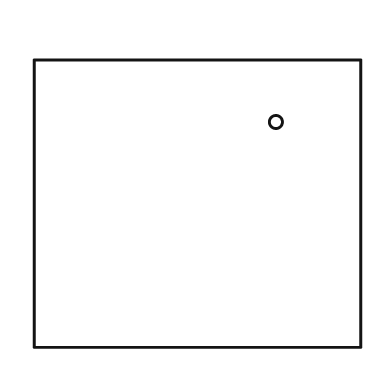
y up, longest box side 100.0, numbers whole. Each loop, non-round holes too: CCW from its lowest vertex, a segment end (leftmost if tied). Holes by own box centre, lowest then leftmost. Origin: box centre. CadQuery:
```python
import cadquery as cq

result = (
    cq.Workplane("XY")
    .moveTo(-50.0, -44.0)
    .lineTo(50.0, -44.0)
    .lineTo(50.0, 44.0)
    .lineTo(-50.0, 44.0)
    .close()
    .moveTo(24.0, 25.0)
    .circle(2.0)
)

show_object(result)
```